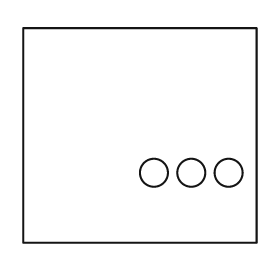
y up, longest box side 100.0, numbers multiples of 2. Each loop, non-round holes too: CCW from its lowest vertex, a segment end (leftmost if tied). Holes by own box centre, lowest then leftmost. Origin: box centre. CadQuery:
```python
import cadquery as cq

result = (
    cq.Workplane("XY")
    .moveTo(-50.0, -46.0)
    .lineTo(50.0, -46.0)
    .lineTo(50.0, 46.0)
    .lineTo(-50.0, 46.0)
    .close()
    .moveTo(6.0, -16.0)
    .circle(6.0)
    .moveTo(22.0, -16.0)
    .circle(6.0)
    .moveTo(38.0, -16.0)
    .circle(6.0)
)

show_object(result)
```